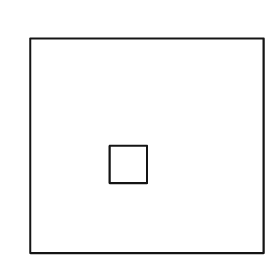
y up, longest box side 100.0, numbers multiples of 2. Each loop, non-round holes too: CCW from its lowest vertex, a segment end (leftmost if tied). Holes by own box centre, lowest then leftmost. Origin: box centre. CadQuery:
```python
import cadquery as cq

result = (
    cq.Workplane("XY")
    .moveTo(-50.0, -46.0)
    .lineTo(50.0, -46.0)
    .lineTo(50.0, 46.0)
    .lineTo(-50.0, 46.0)
    .close()
    .moveTo(-16.0, -16.0)
    .lineTo(0.0, -16.0)
    .lineTo(0.0, 0.0)
    .lineTo(-16.0, 0.0)
    .close()
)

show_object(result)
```